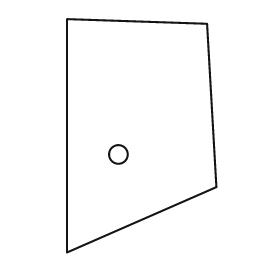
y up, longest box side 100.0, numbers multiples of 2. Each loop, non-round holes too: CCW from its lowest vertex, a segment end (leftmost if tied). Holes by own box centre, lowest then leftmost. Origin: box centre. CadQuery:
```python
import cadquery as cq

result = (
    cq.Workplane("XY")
    .moveTo(-32.0, -50.0)
    .lineTo(32.0, -22.0)
    .lineTo(28.0, 48.0)
    .lineTo(-32.0, 50.0)
    .close()
    .moveTo(-10.0, -8.0)
    .circle(4.0)
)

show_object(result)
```